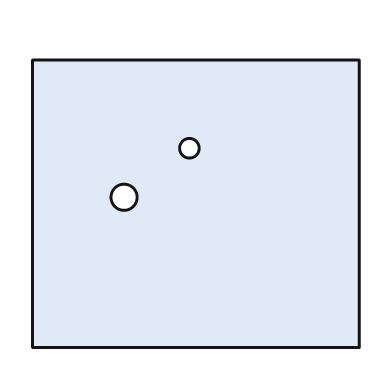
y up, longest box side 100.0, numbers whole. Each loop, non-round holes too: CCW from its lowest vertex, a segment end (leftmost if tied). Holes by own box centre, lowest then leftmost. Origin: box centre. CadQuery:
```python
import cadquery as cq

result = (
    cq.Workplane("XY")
    .moveTo(-50.0, -44.0)
    .lineTo(50.0, -44.0)
    .lineTo(50.0, 44.0)
    .lineTo(-50.0, 44.0)
    .close()
    .moveTo(-22.0, 2.0)
    .circle(4.0)
    .moveTo(-2.0, 17.0)
    .circle(3.0)
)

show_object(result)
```